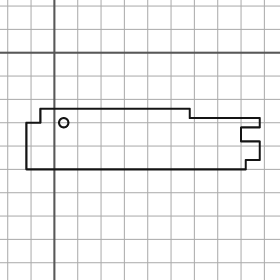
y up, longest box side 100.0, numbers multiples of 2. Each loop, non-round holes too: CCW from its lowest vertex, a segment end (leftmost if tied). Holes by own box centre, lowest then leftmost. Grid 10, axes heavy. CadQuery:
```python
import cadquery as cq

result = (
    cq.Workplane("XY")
    .moveTo(-12.0, -50.0)
    .lineTo(82.0, -50.0)
    .lineTo(82.0, -46.0)
    .lineTo(88.0, -46.0)
    .lineTo(88.0, -38.0)
    .lineTo(80.0, -38.0)
    .lineTo(80.0, -32.0)
    .lineTo(88.0, -32.0)
    .lineTo(88.0, -28.0)
    .lineTo(58.0, -28.0)
    .lineTo(58.0, -24.0)
    .lineTo(-6.0, -24.0)
    .lineTo(-6.0, -30.0)
    .lineTo(-12.0, -30.0)
    .close()
    .moveTo(4.0, -30.0)
    .circle(2.0)
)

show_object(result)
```